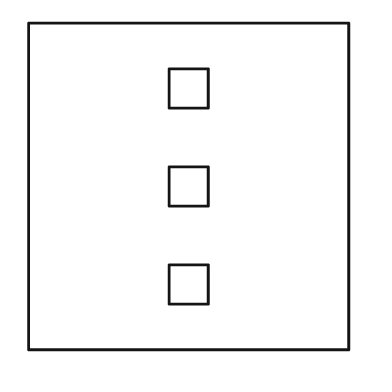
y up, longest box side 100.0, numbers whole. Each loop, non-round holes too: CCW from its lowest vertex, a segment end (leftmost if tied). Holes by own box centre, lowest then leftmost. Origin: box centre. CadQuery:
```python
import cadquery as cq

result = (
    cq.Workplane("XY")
    .moveTo(-49.0, -50.0)
    .lineTo(49.0, -50.0)
    .lineTo(49.0, 50.0)
    .lineTo(-49.0, 50.0)
    .close()
    .moveTo(-6.0, -36.0)
    .lineTo(6.0, -36.0)
    .lineTo(6.0, -24.0)
    .lineTo(-6.0, -24.0)
    .close()
    .moveTo(-6.0, -6.0)
    .lineTo(6.0, -6.0)
    .lineTo(6.0, 6.0)
    .lineTo(-6.0, 6.0)
    .close()
    .moveTo(-6.0, 24.0)
    .lineTo(6.0, 24.0)
    .lineTo(6.0, 36.0)
    .lineTo(-6.0, 36.0)
    .close()
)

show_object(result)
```